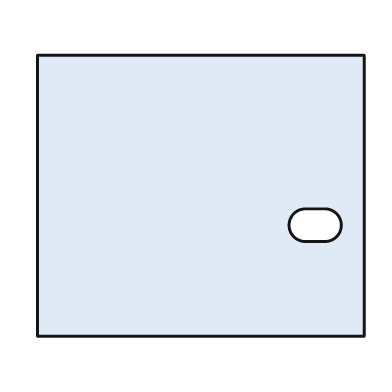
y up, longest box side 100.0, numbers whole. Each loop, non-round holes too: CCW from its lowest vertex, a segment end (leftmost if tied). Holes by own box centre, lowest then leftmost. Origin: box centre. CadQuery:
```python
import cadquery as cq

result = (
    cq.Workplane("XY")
    .moveTo(-50.0, -43.0)
    .lineTo(50.0, -43.0)
    .lineTo(50.0, 43.0)
    .lineTo(-50.0, 43.0)
    .close()
    .moveTo(32.0, -14.0)
    .lineTo(38.0, -14.0)
    .threePointArc((43.0, -9.0), (38.0, -4.0))
    .lineTo(32.0, -4.0)
    .threePointArc((27.0, -9.0), (32.0, -14.0))
    .close()
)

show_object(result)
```